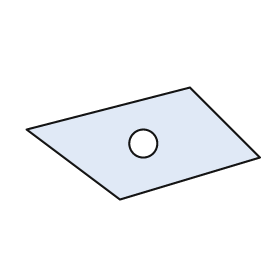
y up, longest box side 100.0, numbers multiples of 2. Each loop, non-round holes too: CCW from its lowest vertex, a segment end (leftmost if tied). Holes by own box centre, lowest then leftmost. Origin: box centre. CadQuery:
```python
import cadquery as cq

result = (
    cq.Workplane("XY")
    .moveTo(-10.0, -24.0)
    .lineTo(50.0, -6.0)
    .lineTo(20.0, 24.0)
    .lineTo(-50.0, 6.0)
    .close()
    .moveTo(0.0, 0.0)
    .circle(6.0)
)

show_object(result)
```